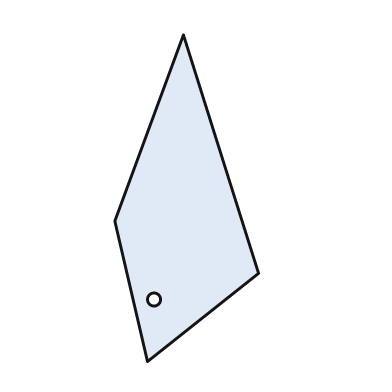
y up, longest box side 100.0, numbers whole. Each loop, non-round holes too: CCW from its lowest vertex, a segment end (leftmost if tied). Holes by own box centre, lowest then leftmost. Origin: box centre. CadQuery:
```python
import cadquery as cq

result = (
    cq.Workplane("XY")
    .moveTo(-12.0, -50.0)
    .lineTo(22.0, -23.0)
    .lineTo(-1.0, 50.0)
    .lineTo(-22.0, -7.0)
    .close()
    .moveTo(-10.0, -31.0)
    .circle(2.0)
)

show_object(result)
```